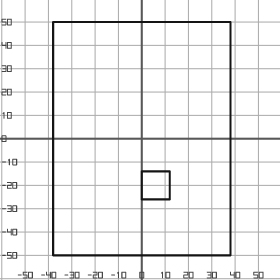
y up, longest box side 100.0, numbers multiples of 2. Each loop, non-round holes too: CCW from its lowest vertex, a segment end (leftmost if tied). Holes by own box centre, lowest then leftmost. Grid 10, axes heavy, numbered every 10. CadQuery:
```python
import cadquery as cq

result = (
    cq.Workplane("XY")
    .moveTo(-38.0, -50.0)
    .lineTo(38.0, -50.0)
    .lineTo(38.0, 50.0)
    .lineTo(-38.0, 50.0)
    .close()
    .moveTo(0.0, -26.0)
    .lineTo(12.0, -26.0)
    .lineTo(12.0, -14.0)
    .lineTo(0.0, -14.0)
    .close()
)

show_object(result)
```